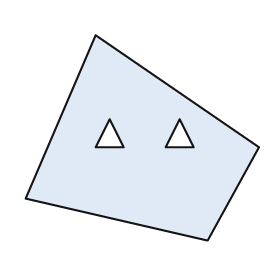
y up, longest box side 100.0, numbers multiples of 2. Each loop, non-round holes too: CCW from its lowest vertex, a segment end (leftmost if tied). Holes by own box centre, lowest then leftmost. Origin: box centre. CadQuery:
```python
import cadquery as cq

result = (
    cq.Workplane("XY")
    .moveTo(28.0, -44.0)
    .lineTo(50.0, -4.0)
    .lineTo(-20.0, 44.0)
    .lineTo(-50.0, -26.0)
    .close()
    .moveTo(-20.0, -4.0)
    .lineTo(-8.0, -4.0)
    .lineTo(-14.0, 8.0)
    .close()
    .moveTo(10.0, -4.0)
    .lineTo(22.0, -4.0)
    .lineTo(16.0, 8.0)
    .close()
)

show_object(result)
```